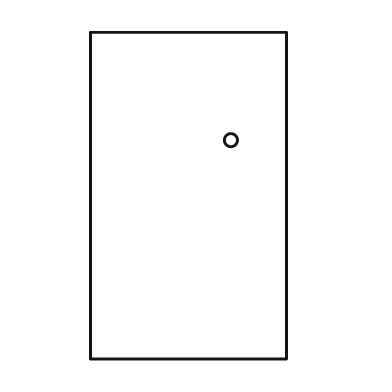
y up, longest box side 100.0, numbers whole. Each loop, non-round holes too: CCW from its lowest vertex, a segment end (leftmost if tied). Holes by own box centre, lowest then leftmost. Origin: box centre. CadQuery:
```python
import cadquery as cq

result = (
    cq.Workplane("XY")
    .moveTo(-30.0, -50.0)
    .lineTo(30.0, -50.0)
    .lineTo(30.0, 50.0)
    .lineTo(-30.0, 50.0)
    .close()
    .moveTo(13.0, 17.0)
    .circle(2.0)
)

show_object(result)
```